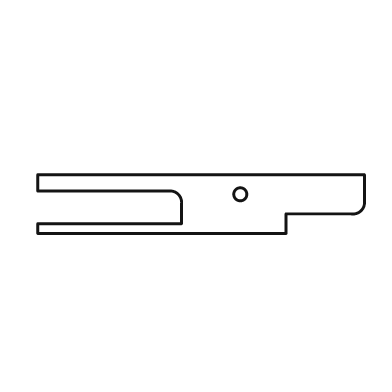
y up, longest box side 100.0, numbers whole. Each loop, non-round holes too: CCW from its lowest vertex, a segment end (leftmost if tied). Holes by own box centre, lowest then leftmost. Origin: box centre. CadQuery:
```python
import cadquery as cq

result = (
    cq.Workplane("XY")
    .moveTo(-50.0, -9.0)
    .lineTo(26.0, -9.0)
    .lineTo(26.0, -3.0)
    .lineTo(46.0, -3.0)
    .threePointArc((49.0, -2.0), (50.0, 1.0))
    .lineTo(50.0, 9.0)
    .lineTo(-50.0, 9.0)
    .lineTo(-50.0, 4.0)
    .lineTo(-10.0, 4.0)
    .threePointArc((-7.0, 3.0), (-6.0, 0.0))
    .lineTo(-6.0, -6.0)
    .lineTo(-50.0, -6.0)
    .close()
    .moveTo(12.0, 3.0)
    .circle(2.0)
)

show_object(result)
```